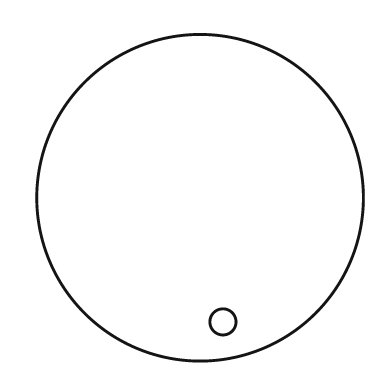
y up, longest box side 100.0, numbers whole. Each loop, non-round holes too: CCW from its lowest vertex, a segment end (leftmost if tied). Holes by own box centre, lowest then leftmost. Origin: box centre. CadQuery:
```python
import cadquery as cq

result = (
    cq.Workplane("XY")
    .moveTo(0.0, 0.0)
    .circle(50.0)
    .moveTo(7.0, -38.0)
    .circle(4.0)
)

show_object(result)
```